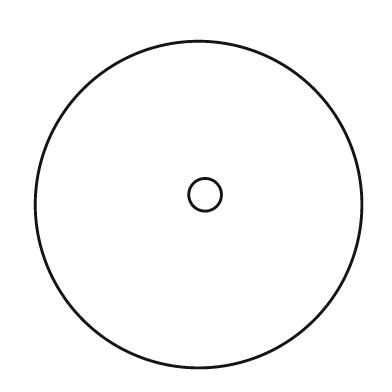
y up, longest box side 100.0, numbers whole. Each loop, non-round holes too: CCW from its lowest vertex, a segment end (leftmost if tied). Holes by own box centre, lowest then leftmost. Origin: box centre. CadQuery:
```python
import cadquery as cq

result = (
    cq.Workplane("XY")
    .moveTo(0.0, 0.0)
    .circle(50.0)
    .moveTo(2.0, 3.0)
    .circle(5.0)
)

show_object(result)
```